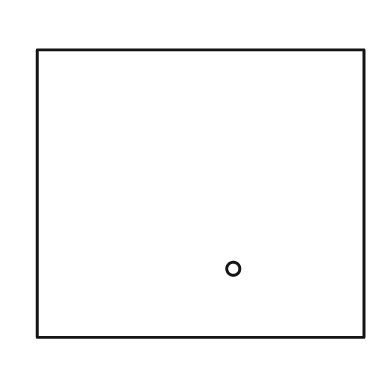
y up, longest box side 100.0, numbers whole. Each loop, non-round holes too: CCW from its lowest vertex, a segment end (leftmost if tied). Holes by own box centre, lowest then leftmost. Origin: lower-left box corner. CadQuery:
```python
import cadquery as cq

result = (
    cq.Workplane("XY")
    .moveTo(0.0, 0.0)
    .lineTo(100.0, 0.0)
    .lineTo(100.0, 88.0)
    .lineTo(0.0, 88.0)
    .close()
    .moveTo(60.0, 21.0)
    .circle(2.0)
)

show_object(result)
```